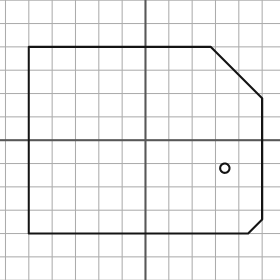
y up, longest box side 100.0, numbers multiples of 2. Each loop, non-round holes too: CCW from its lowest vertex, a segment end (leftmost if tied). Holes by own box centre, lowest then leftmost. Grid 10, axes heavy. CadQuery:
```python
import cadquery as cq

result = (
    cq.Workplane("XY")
    .moveTo(-50.0, -40.0)
    .lineTo(44.0, -40.0)
    .lineTo(50.0, -34.0)
    .lineTo(50.0, 18.0)
    .lineTo(28.0, 40.0)
    .lineTo(-50.0, 40.0)
    .close()
    .moveTo(34.0, -12.0)
    .circle(2.0)
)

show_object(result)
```